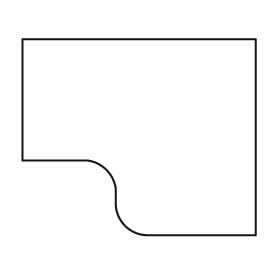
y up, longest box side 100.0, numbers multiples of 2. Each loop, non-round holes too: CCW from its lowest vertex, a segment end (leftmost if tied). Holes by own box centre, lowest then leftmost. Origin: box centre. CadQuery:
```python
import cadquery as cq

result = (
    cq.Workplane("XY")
    .moveTo(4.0, -42.0)
    .lineTo(50.0, -42.0)
    .lineTo(50.0, 42.0)
    .lineTo(-50.0, 42.0)
    .lineTo(-50.0, -10.0)
    .lineTo(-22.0, -10.0)
    .threePointArc((-14.0, -14.0), (-10.0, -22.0))
    .lineTo(-10.0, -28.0)
    .threePointArc((-6.0, -38.0), (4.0, -42.0))
    .close()
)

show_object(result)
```